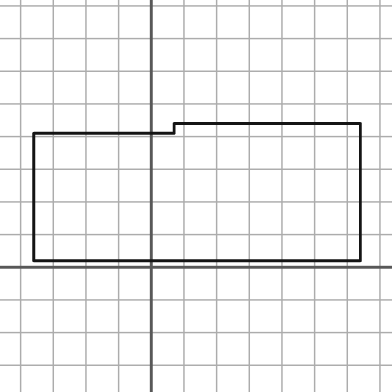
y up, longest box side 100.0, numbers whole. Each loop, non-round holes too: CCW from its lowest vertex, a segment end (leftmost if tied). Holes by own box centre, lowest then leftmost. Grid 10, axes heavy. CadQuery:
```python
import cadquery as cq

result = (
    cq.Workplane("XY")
    .moveTo(-36.0, 2.0)
    .lineTo(64.0, 2.0)
    .lineTo(64.0, 44.0)
    .lineTo(7.0, 44.0)
    .lineTo(7.0, 41.0)
    .lineTo(-36.0, 41.0)
    .close()
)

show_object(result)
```